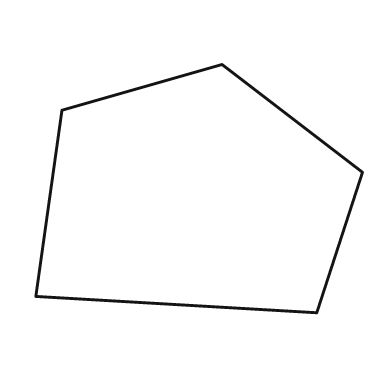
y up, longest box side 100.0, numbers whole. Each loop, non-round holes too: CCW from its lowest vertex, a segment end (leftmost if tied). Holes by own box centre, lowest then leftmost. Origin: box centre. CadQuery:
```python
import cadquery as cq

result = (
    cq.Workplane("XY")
    .moveTo(36.0, -38.0)
    .lineTo(50.0, 5.0)
    .lineTo(7.0, 38.0)
    .lineTo(-42.0, 24.0)
    .lineTo(-50.0, -33.0)
    .close()
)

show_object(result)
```